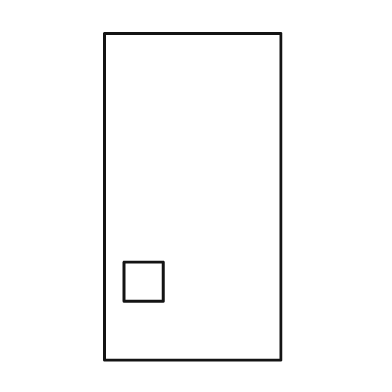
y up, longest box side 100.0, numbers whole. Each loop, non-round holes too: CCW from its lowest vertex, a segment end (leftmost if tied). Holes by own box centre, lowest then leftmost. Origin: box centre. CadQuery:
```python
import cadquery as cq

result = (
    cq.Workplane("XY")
    .moveTo(-27.0, -50.0)
    .lineTo(27.0, -50.0)
    .lineTo(27.0, 50.0)
    .lineTo(-27.0, 50.0)
    .close()
    .moveTo(-21.0, -32.0)
    .lineTo(-9.0, -32.0)
    .lineTo(-9.0, -20.0)
    .lineTo(-21.0, -20.0)
    .close()
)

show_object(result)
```